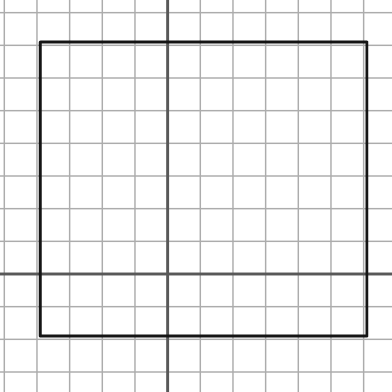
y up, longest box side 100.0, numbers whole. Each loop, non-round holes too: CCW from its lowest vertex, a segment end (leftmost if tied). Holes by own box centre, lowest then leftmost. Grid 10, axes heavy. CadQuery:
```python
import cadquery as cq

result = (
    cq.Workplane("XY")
    .moveTo(-39.0, -19.0)
    .lineTo(61.0, -19.0)
    .lineTo(61.0, 71.0)
    .lineTo(-39.0, 71.0)
    .close()
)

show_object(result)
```